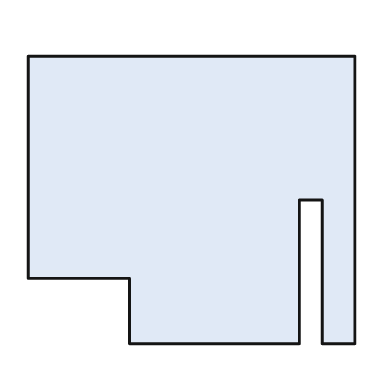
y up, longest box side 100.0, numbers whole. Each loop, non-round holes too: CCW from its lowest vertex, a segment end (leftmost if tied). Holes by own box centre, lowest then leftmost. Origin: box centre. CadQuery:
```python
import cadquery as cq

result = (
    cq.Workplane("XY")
    .moveTo(-19.0, -44.0)
    .lineTo(33.0, -44.0)
    .lineTo(33.0, 0.0)
    .lineTo(40.0, 0.0)
    .lineTo(40.0, -44.0)
    .lineTo(50.0, -44.0)
    .lineTo(50.0, 44.0)
    .lineTo(-50.0, 44.0)
    .lineTo(-50.0, -24.0)
    .lineTo(-19.0, -24.0)
    .close()
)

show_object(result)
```